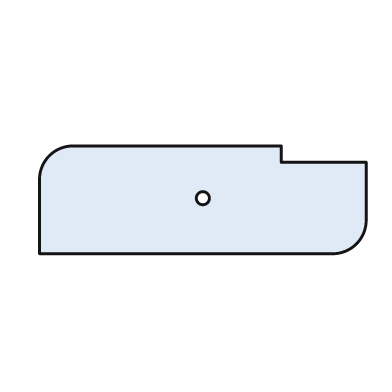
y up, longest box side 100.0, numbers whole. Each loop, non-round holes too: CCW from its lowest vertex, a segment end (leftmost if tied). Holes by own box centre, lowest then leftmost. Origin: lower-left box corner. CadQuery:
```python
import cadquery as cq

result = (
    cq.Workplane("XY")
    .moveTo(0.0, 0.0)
    .lineTo(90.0, 0.0)
    .threePointArc((97.0, 3.0), (100.0, 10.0))
    .lineTo(100.0, 28.0)
    .lineTo(74.0, 28.0)
    .lineTo(74.0, 33.0)
    .lineTo(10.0, 33.0)
    .threePointArc((3.0, 30.0), (0.0, 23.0))
    .close()
    .moveTo(50.0, 17.0)
    .circle(2.0)
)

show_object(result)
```